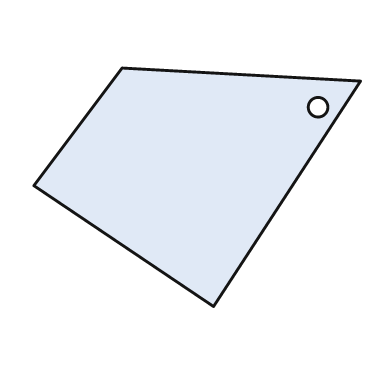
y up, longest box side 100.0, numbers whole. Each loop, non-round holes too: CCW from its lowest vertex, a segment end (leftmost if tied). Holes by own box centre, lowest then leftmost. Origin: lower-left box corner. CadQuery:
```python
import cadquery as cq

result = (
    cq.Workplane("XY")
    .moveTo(55.0, 0.0)
    .lineTo(100.0, 69.0)
    .lineTo(27.0, 73.0)
    .lineTo(0.0, 37.0)
    .close()
    .moveTo(87.0, 61.0)
    .circle(3.0)
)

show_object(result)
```